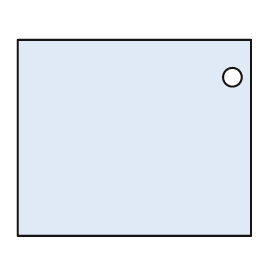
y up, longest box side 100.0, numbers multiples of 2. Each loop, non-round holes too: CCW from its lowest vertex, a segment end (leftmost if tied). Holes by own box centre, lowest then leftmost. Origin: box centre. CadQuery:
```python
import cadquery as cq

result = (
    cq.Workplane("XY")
    .moveTo(-50.0, -42.0)
    .lineTo(50.0, -42.0)
    .lineTo(50.0, 42.0)
    .lineTo(-50.0, 42.0)
    .close()
    .moveTo(42.0, 26.0)
    .circle(4.0)
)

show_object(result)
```